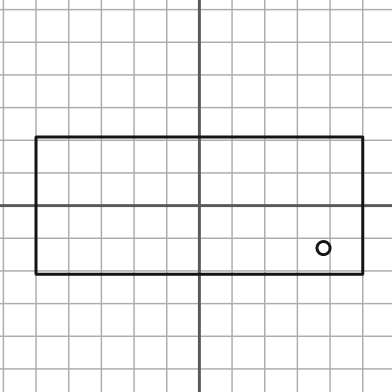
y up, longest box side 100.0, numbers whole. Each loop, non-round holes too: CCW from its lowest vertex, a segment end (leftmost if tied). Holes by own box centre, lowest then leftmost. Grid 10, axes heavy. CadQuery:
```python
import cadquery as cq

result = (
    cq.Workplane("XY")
    .moveTo(-50.0, -21.0)
    .lineTo(50.0, -21.0)
    .lineTo(50.0, 21.0)
    .lineTo(-50.0, 21.0)
    .close()
    .moveTo(38.0, -13.0)
    .circle(2.0)
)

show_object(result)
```